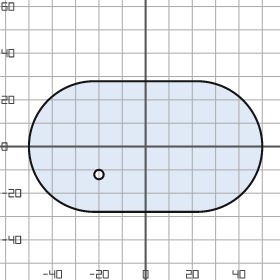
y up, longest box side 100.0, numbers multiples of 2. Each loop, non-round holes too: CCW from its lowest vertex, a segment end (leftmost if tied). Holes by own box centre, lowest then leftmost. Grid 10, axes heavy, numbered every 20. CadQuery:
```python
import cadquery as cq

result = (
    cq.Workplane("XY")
    .moveTo(-22.0, -28.0)
    .lineTo(22.0, -28.0)
    .threePointArc((50.0, 0.0), (22.0, 28.0))
    .lineTo(-22.0, 28.0)
    .threePointArc((-50.0, 0.0), (-22.0, -28.0))
    .close()
    .moveTo(-20.0, -12.0)
    .circle(2.0)
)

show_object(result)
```